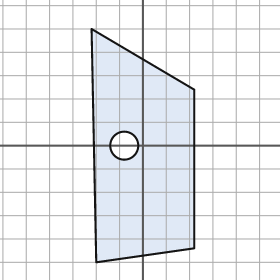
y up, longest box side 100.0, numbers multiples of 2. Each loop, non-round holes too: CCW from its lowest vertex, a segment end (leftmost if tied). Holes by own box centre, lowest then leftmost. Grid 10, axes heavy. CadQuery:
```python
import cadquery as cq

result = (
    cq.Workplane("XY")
    .moveTo(-20.0, -50.0)
    .lineTo(22.0, -44.0)
    .lineTo(22.0, 24.0)
    .lineTo(-22.0, 50.0)
    .close()
    .moveTo(-8.0, 0.0)
    .circle(6.0)
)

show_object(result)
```